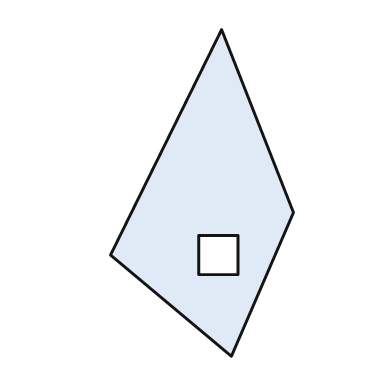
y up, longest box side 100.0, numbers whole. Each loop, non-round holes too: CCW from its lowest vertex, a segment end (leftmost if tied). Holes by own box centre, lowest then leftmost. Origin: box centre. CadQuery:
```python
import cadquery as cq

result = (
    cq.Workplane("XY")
    .moveTo(9.0, -50.0)
    .lineTo(28.0, -6.0)
    .lineTo(6.0, 50.0)
    .lineTo(-28.0, -19.0)
    .close()
    .moveTo(-1.0, -25.0)
    .lineTo(11.0, -25.0)
    .lineTo(11.0, -13.0)
    .lineTo(-1.0, -13.0)
    .close()
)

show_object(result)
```